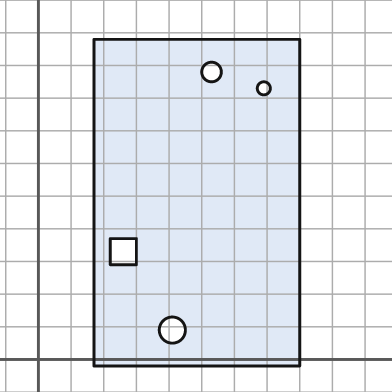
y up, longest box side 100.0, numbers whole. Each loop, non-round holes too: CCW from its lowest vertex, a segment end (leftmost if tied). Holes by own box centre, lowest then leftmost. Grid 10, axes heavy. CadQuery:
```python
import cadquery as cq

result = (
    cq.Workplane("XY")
    .moveTo(17.0, -2.0)
    .lineTo(80.0, -2.0)
    .lineTo(80.0, 98.0)
    .lineTo(17.0, 98.0)
    .close()
    .moveTo(41.0, 9.0)
    .circle(4.0)
    .moveTo(22.0, 29.0)
    .lineTo(30.0, 29.0)
    .lineTo(30.0, 37.0)
    .lineTo(22.0, 37.0)
    .close()
    .moveTo(69.0, 83.0)
    .circle(2.0)
    .moveTo(53.0, 88.0)
    .circle(3.0)
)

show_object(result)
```